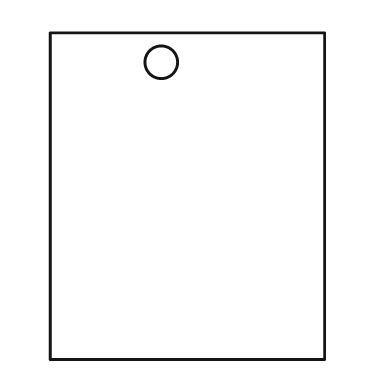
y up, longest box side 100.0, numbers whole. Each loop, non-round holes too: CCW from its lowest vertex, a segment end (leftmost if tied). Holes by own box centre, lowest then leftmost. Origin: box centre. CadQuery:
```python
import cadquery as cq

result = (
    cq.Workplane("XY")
    .moveTo(-42.0, -50.0)
    .lineTo(42.0, -50.0)
    .lineTo(42.0, 50.0)
    .lineTo(-42.0, 50.0)
    .close()
    .moveTo(-8.0, 41.0)
    .circle(5.0)
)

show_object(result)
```